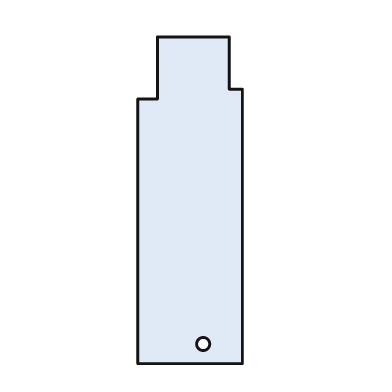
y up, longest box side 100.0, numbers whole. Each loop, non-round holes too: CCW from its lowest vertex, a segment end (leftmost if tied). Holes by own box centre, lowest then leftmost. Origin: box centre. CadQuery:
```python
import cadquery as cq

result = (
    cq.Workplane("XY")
    .moveTo(-16.0, -50.0)
    .lineTo(16.0, -50.0)
    .lineTo(16.0, 34.0)
    .lineTo(12.0, 34.0)
    .lineTo(12.0, 50.0)
    .lineTo(-10.0, 50.0)
    .lineTo(-10.0, 31.0)
    .lineTo(-16.0, 31.0)
    .close()
    .moveTo(4.0, -44.0)
    .circle(2.0)
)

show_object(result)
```